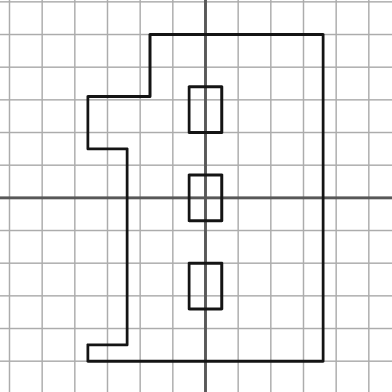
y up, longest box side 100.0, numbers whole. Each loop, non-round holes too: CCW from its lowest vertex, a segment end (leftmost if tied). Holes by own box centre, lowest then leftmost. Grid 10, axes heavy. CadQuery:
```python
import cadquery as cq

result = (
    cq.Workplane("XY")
    .moveTo(-36.0, -50.0)
    .lineTo(36.0, -50.0)
    .lineTo(36.0, 50.0)
    .lineTo(-17.0, 50.0)
    .lineTo(-17.0, 31.0)
    .lineTo(-36.0, 31.0)
    .lineTo(-36.0, 15.0)
    .lineTo(-24.0, 15.0)
    .lineTo(-24.0, -45.0)
    .lineTo(-36.0, -45.0)
    .close()
    .moveTo(-5.0, -34.0)
    .lineTo(5.0, -34.0)
    .lineTo(5.0, -20.0)
    .lineTo(-5.0, -20.0)
    .close()
    .moveTo(-5.0, -7.0)
    .lineTo(5.0, -7.0)
    .lineTo(5.0, 7.0)
    .lineTo(-5.0, 7.0)
    .close()
    .moveTo(-5.0, 20.0)
    .lineTo(5.0, 20.0)
    .lineTo(5.0, 34.0)
    .lineTo(-5.0, 34.0)
    .close()
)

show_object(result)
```